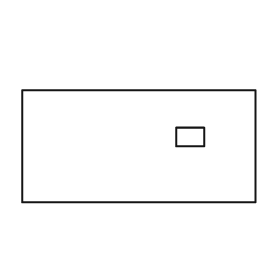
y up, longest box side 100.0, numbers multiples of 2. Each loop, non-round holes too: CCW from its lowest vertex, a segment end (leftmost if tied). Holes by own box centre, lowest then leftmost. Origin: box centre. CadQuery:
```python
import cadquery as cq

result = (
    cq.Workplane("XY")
    .moveTo(-50.0, -24.0)
    .lineTo(50.0, -24.0)
    .lineTo(50.0, 24.0)
    .lineTo(-50.0, 24.0)
    .close()
    .moveTo(16.0, 0.0)
    .lineTo(28.0, 0.0)
    .lineTo(28.0, 8.0)
    .lineTo(16.0, 8.0)
    .close()
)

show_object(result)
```